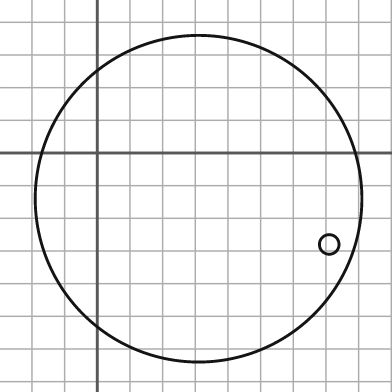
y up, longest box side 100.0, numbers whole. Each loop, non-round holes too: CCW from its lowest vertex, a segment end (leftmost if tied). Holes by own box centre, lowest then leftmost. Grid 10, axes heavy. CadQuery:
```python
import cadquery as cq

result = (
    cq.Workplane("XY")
    .moveTo(31.0, -14.0)
    .circle(50.0)
    .moveTo(71.0, -28.0)
    .circle(3.0)
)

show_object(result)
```